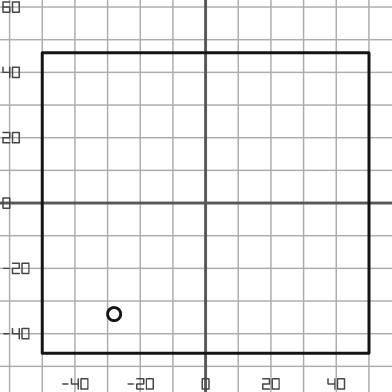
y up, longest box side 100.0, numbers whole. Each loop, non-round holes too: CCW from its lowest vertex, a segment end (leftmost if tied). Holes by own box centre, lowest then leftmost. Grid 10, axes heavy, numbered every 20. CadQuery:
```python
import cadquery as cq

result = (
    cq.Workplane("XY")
    .moveTo(-50.0, -46.0)
    .lineTo(50.0, -46.0)
    .lineTo(50.0, 46.0)
    .lineTo(-50.0, 46.0)
    .close()
    .moveTo(-28.0, -34.0)
    .circle(2.0)
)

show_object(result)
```